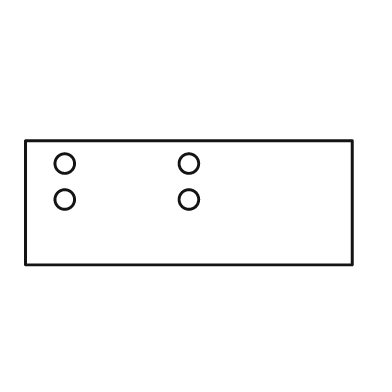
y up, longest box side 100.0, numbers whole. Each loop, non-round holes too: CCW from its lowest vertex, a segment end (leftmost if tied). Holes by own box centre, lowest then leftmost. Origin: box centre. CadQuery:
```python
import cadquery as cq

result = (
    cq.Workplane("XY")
    .moveTo(-50.0, -19.0)
    .lineTo(50.0, -19.0)
    .lineTo(50.0, 19.0)
    .lineTo(-50.0, 19.0)
    .close()
    .moveTo(-38.0, 1.0)
    .circle(3.0)
    .moveTo(0.0, 1.0)
    .circle(3.0)
    .moveTo(-38.0, 12.0)
    .circle(3.0)
    .moveTo(0.0, 12.0)
    .circle(3.0)
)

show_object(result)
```